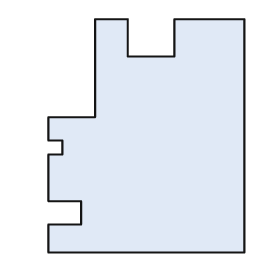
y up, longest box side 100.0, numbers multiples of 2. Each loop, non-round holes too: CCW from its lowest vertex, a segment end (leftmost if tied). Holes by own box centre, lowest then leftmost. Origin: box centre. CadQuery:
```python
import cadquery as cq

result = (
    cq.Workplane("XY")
    .moveTo(-42.0, -50.0)
    .lineTo(42.0, -50.0)
    .lineTo(42.0, 50.0)
    .lineTo(12.0, 50.0)
    .lineTo(12.0, 34.0)
    .lineTo(-8.0, 34.0)
    .lineTo(-8.0, 50.0)
    .lineTo(-22.0, 50.0)
    .lineTo(-22.0, 8.0)
    .lineTo(-42.0, 8.0)
    .lineTo(-42.0, -2.0)
    .lineTo(-36.0, -2.0)
    .lineTo(-36.0, -8.0)
    .lineTo(-42.0, -8.0)
    .lineTo(-42.0, -28.0)
    .lineTo(-28.0, -28.0)
    .lineTo(-28.0, -38.0)
    .lineTo(-42.0, -38.0)
    .close()
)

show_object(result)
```